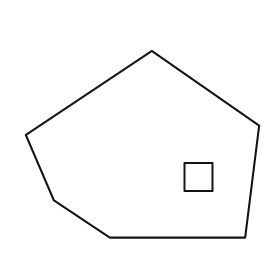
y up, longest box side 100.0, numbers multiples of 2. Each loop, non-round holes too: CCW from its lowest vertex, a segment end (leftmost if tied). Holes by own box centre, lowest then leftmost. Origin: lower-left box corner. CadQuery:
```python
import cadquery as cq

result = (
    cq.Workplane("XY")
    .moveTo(36.0, 0.0)
    .lineTo(94.0, 0.0)
    .lineTo(100.0, 48.0)
    .lineTo(54.0, 80.0)
    .lineTo(0.0, 44.0)
    .lineTo(12.0, 16.0)
    .close()
    .moveTo(68.0, 20.0)
    .lineTo(80.0, 20.0)
    .lineTo(80.0, 32.0)
    .lineTo(68.0, 32.0)
    .close()
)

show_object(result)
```